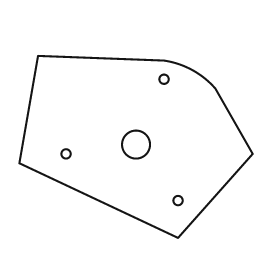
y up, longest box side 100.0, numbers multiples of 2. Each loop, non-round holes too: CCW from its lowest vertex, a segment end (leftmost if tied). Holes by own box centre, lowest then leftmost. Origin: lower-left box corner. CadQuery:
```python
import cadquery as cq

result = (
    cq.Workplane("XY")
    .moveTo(68.0, 0.0)
    .lineTo(100.0, 36.0)
    .lineTo(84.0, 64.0)
    .threePointArc((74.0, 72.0), (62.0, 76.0))
    .lineTo(8.0, 78.0)
    .lineTo(0.0, 32.0)
    .close()
    .moveTo(68.0, 16.0)
    .circle(2.0)
    .moveTo(20.0, 36.0)
    .circle(2.0)
    .moveTo(50.0, 40.0)
    .circle(6.0)
    .moveTo(62.0, 68.0)
    .circle(2.0)
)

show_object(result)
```